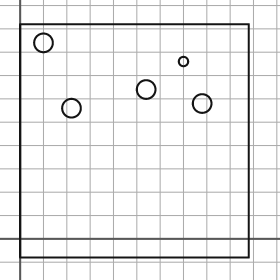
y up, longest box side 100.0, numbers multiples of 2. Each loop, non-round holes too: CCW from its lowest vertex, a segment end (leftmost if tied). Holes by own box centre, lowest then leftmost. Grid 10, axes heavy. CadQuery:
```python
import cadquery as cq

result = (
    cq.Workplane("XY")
    .moveTo(0.0, -8.0)
    .lineTo(98.0, -8.0)
    .lineTo(98.0, 92.0)
    .lineTo(0.0, 92.0)
    .close()
    .moveTo(22.0, 56.0)
    .circle(4.0)
    .moveTo(78.0, 58.0)
    .circle(4.0)
    .moveTo(54.0, 64.0)
    .circle(4.0)
    .moveTo(70.0, 76.0)
    .circle(2.0)
    .moveTo(10.0, 84.0)
    .circle(4.0)
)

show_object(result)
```